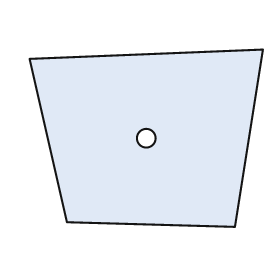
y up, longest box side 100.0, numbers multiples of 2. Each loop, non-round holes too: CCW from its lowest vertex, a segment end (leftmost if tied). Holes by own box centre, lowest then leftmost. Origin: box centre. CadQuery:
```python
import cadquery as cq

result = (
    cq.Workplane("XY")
    .moveTo(38.0, -38.0)
    .lineTo(50.0, 38.0)
    .lineTo(-50.0, 34.0)
    .lineTo(-34.0, -36.0)
    .close()
    .moveTo(0.0, 0.0)
    .circle(4.0)
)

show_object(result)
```